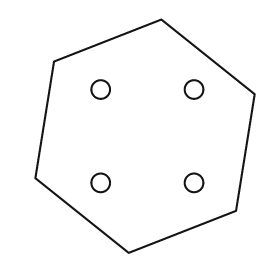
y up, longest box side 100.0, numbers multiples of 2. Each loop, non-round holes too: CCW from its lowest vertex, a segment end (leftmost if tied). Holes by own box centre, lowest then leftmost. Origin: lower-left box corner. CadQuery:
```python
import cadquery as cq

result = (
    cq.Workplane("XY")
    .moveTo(40.0, 0.0)
    .lineTo(86.0, 18.0)
    .lineTo(94.0, 68.0)
    .lineTo(54.0, 100.0)
    .lineTo(8.0, 82.0)
    .lineTo(0.0, 32.0)
    .close()
    .moveTo(28.0, 30.0)
    .circle(4.0)
    .moveTo(68.0, 30.0)
    .circle(4.0)
    .moveTo(28.0, 70.0)
    .circle(4.0)
    .moveTo(68.0, 70.0)
    .circle(4.0)
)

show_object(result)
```